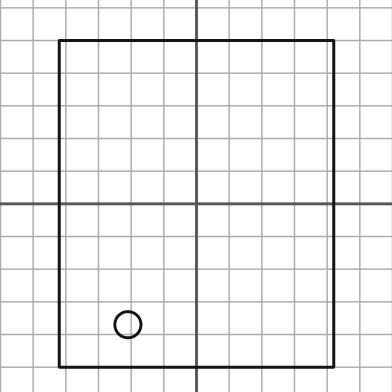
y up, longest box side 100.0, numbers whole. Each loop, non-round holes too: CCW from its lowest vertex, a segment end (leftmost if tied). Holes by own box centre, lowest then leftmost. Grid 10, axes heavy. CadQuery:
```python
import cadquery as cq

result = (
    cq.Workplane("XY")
    .moveTo(-42.0, -50.0)
    .lineTo(42.0, -50.0)
    .lineTo(42.0, 50.0)
    .lineTo(-42.0, 50.0)
    .close()
    .moveTo(-21.0, -37.0)
    .circle(4.0)
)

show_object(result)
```